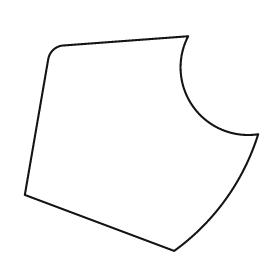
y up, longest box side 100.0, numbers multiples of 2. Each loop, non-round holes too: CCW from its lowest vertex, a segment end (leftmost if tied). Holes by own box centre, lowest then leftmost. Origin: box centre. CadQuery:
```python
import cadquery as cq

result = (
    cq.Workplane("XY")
    .moveTo(14.0, -46.0)
    .threePointArc((36.0, -24.0), (50.0, 4.0))
    .threePointArc((22.0, 16.0), (20.0, 46.0))
    .lineTo(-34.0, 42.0)
    .threePointArc((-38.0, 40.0), (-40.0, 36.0))
    .lineTo(-50.0, -22.0)
    .close()
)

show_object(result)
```